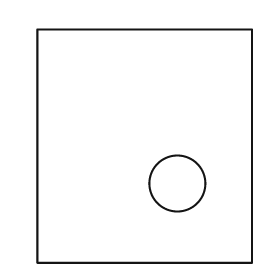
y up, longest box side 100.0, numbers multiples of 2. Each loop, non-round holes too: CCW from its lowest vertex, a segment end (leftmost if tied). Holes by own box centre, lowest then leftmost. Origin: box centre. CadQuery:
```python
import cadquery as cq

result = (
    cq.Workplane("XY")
    .moveTo(-46.0, -50.0)
    .lineTo(46.0, -50.0)
    .lineTo(46.0, 50.0)
    .lineTo(-46.0, 50.0)
    .close()
    .moveTo(14.0, -16.0)
    .circle(12.0)
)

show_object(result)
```